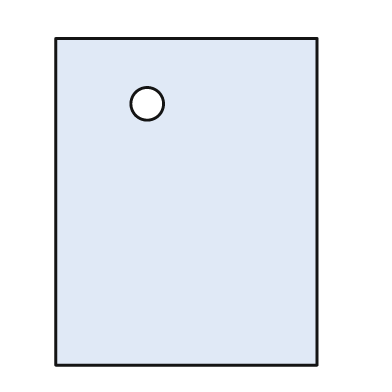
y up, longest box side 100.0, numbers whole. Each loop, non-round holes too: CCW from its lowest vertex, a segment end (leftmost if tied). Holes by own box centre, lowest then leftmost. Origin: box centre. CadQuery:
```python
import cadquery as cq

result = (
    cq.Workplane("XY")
    .moveTo(-40.0, -50.0)
    .lineTo(40.0, -50.0)
    .lineTo(40.0, 50.0)
    .lineTo(-40.0, 50.0)
    .close()
    .moveTo(-12.0, 30.0)
    .circle(5.0)
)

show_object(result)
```